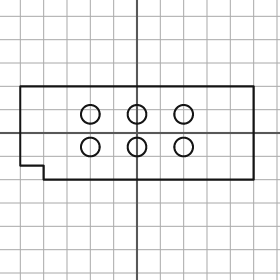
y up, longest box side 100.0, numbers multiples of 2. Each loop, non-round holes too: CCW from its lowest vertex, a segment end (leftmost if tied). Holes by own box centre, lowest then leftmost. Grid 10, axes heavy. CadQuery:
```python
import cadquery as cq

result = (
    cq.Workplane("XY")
    .moveTo(-40.0, -20.0)
    .lineTo(50.0, -20.0)
    .lineTo(50.0, 20.0)
    .lineTo(-50.0, 20.0)
    .lineTo(-50.0, -14.0)
    .lineTo(-40.0, -14.0)
    .close()
    .moveTo(-20.0, -6.0)
    .circle(4.0)
    .moveTo(0.0, -6.0)
    .circle(4.0)
    .moveTo(20.0, -6.0)
    .circle(4.0)
    .moveTo(-20.0, 8.0)
    .circle(4.0)
    .moveTo(0.0, 8.0)
    .circle(4.0)
    .moveTo(20.0, 8.0)
    .circle(4.0)
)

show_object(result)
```